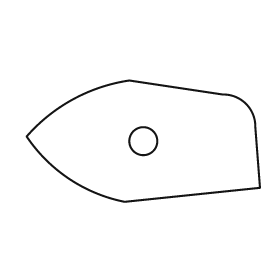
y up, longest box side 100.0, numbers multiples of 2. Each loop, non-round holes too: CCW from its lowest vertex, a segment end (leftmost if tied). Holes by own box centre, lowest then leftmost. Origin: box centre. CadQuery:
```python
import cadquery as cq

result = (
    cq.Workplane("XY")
    .moveTo(-8.0, -26.0)
    .lineTo(50.0, -20.0)
    .lineTo(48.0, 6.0)
    .threePointArc((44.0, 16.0), (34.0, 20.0))
    .lineTo(-6.0, 26.0)
    .threePointArc((-30.0, 18.0), (-50.0, 2.0))
    .threePointArc((-32.0, -16.0), (-8.0, -26.0))
    .close()
    .moveTo(0.0, 0.0)
    .circle(6.0)
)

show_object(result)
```